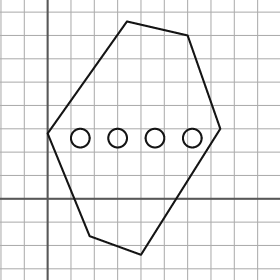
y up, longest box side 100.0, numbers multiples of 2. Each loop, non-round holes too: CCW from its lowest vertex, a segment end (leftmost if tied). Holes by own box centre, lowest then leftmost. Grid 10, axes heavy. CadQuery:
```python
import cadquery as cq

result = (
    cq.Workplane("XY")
    .moveTo(40.0, -24.0)
    .lineTo(74.0, 30.0)
    .lineTo(60.0, 70.0)
    .lineTo(34.0, 76.0)
    .lineTo(0.0, 28.0)
    .lineTo(18.0, -16.0)
    .close()
    .moveTo(14.0, 26.0)
    .circle(4.0)
    .moveTo(30.0, 26.0)
    .circle(4.0)
    .moveTo(46.0, 26.0)
    .circle(4.0)
    .moveTo(62.0, 26.0)
    .circle(4.0)
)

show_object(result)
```